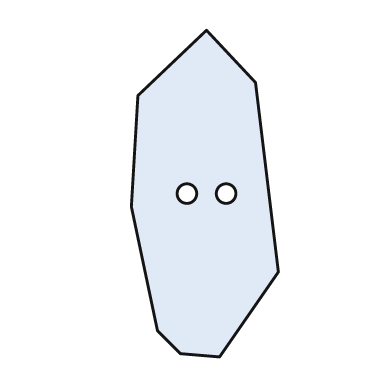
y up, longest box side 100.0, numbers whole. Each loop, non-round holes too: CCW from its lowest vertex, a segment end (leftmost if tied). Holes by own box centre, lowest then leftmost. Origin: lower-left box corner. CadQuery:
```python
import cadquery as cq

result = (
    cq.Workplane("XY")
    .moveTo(27.0, 0.0)
    .lineTo(45.0, 26.0)
    .lineTo(38.0, 84.0)
    .lineTo(23.0, 100.0)
    .lineTo(2.0, 80.0)
    .lineTo(0.0, 46.0)
    .lineTo(8.0, 8.0)
    .lineTo(15.0, 1.0)
    .close()
    .moveTo(17.0, 50.0)
    .circle(3.0)
    .moveTo(29.0, 50.0)
    .circle(3.0)
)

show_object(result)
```